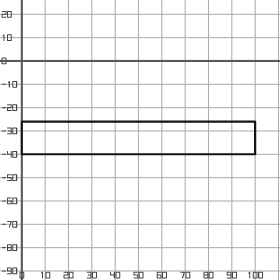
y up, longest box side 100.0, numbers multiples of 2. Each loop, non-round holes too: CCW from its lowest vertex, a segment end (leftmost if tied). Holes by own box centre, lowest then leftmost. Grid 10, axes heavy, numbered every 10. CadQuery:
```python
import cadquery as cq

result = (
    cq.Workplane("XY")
    .moveTo(0.0, -40.0)
    .lineTo(100.0, -40.0)
    .lineTo(100.0, -26.0)
    .lineTo(0.0, -26.0)
    .close()
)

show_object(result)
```